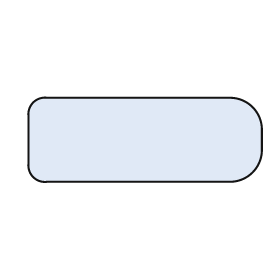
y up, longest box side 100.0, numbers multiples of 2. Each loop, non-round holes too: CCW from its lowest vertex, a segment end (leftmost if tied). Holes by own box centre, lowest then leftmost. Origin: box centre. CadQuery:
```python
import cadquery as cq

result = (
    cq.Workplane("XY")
    .moveTo(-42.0, -18.0)
    .lineTo(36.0, -18.0)
    .threePointArc((46.0, -14.0), (50.0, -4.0))
    .lineTo(50.0, 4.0)
    .threePointArc((46.0, 14.0), (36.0, 18.0))
    .lineTo(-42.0, 18.0)
    .threePointArc((-48.0, 16.0), (-50.0, 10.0))
    .lineTo(-50.0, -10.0)
    .threePointArc((-48.0, -16.0), (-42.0, -18.0))
    .close()
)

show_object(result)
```